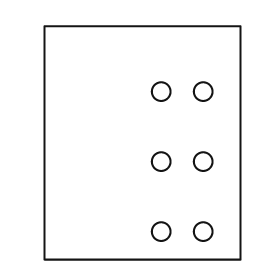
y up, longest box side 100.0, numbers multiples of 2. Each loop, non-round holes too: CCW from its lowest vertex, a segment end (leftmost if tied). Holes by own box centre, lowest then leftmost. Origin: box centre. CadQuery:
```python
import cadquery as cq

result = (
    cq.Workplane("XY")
    .moveTo(-42.0, -50.0)
    .lineTo(42.0, -50.0)
    .lineTo(42.0, 50.0)
    .lineTo(-42.0, 50.0)
    .close()
    .moveTo(8.0, -38.0)
    .circle(4.0)
    .moveTo(26.0, -38.0)
    .circle(4.0)
    .moveTo(8.0, -8.0)
    .circle(4.0)
    .moveTo(26.0, -8.0)
    .circle(4.0)
    .moveTo(8.0, 22.0)
    .circle(4.0)
    .moveTo(26.0, 22.0)
    .circle(4.0)
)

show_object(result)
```